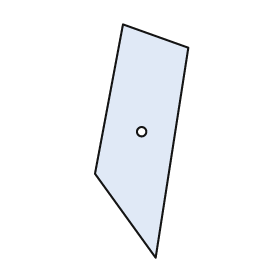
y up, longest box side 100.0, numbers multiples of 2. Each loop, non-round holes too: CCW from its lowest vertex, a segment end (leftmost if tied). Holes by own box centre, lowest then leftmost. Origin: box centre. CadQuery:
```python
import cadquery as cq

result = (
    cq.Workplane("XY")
    .moveTo(6.0, -50.0)
    .lineTo(20.0, 40.0)
    .lineTo(-8.0, 50.0)
    .lineTo(-20.0, -14.0)
    .close()
    .moveTo(0.0, 4.0)
    .circle(2.0)
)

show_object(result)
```